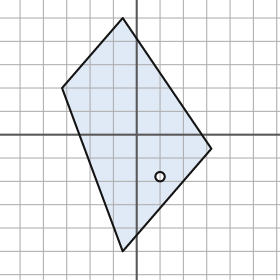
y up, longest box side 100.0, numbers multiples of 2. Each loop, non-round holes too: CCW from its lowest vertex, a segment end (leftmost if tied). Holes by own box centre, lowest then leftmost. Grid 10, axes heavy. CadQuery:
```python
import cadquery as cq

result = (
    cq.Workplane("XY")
    .moveTo(-6.0, -50.0)
    .lineTo(32.0, -6.0)
    .lineTo(-6.0, 50.0)
    .lineTo(-32.0, 20.0)
    .close()
    .moveTo(10.0, -18.0)
    .circle(2.0)
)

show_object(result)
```